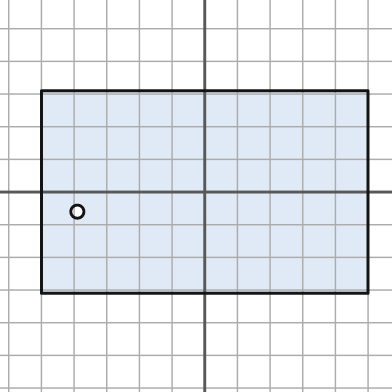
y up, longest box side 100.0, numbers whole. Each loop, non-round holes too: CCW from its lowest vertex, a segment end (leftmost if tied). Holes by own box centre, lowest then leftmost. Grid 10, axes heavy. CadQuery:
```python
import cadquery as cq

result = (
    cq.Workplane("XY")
    .moveTo(-50.0, -31.0)
    .lineTo(50.0, -31.0)
    .lineTo(50.0, 31.0)
    .lineTo(-50.0, 31.0)
    .close()
    .moveTo(-39.0, -6.0)
    .circle(2.0)
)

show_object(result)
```